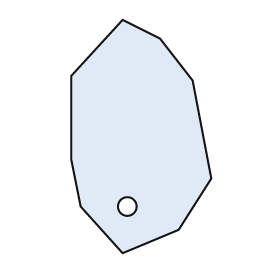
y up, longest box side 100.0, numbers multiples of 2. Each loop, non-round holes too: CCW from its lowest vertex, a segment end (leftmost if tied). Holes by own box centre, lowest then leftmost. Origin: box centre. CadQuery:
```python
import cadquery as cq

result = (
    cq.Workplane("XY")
    .moveTo(-8.0, -50.0)
    .lineTo(16.0, -40.0)
    .lineTo(30.0, -18.0)
    .lineTo(22.0, 24.0)
    .lineTo(8.0, 42.0)
    .lineTo(-8.0, 50.0)
    .lineTo(-30.0, 26.0)
    .lineTo(-30.0, -10.0)
    .lineTo(-26.0, -30.0)
    .close()
    .moveTo(-6.0, -30.0)
    .circle(4.0)
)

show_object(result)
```